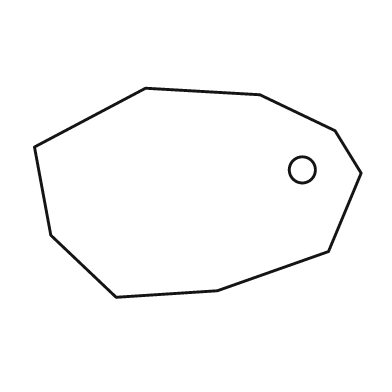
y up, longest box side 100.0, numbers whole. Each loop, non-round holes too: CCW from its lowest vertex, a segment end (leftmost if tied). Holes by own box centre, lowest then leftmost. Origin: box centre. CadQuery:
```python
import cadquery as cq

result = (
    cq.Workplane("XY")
    .moveTo(-25.0, -32.0)
    .lineTo(6.0, -30.0)
    .lineTo(40.0, -18.0)
    .lineTo(50.0, 6.0)
    .lineTo(42.0, 19.0)
    .lineTo(19.0, 30.0)
    .lineTo(-16.0, 32.0)
    .lineTo(-50.0, 14.0)
    .lineTo(-45.0, -13.0)
    .close()
    .moveTo(32.0, 7.0)
    .circle(4.0)
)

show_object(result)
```